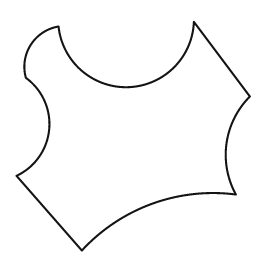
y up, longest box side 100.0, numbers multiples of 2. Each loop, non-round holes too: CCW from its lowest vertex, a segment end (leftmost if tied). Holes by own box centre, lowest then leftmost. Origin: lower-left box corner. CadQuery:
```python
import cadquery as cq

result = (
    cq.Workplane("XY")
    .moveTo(28.0, 0.0)
    .threePointArc((58.0, 20.0), (94.0, 24.0))
    .threePointArc((90.0, 46.0), (100.0, 66.0))
    .lineTo(76.0, 98.0)
    .threePointArc((48.0, 70.0), (18.0, 96.0))
    .threePointArc((6.0, 88.0), (4.0, 74.0))
    .threePointArc((14.0, 52.0), (0.0, 32.0))
    .close()
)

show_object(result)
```